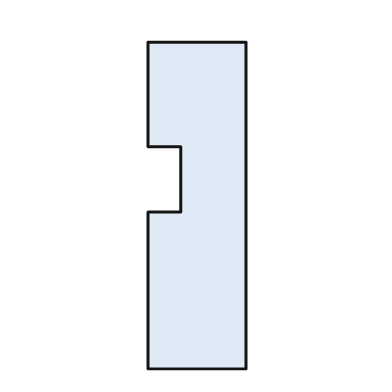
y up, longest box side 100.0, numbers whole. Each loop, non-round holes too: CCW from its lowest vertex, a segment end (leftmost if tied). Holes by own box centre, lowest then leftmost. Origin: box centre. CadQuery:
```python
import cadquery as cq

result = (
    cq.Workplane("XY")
    .moveTo(-15.0, -50.0)
    .lineTo(15.0, -50.0)
    .lineTo(15.0, 50.0)
    .lineTo(-15.0, 50.0)
    .lineTo(-15.0, 18.0)
    .lineTo(-5.0, 18.0)
    .lineTo(-5.0, -2.0)
    .lineTo(-15.0, -2.0)
    .close()
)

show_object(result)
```